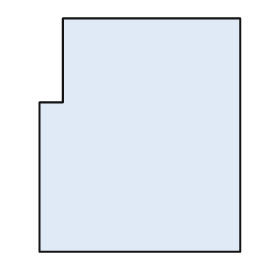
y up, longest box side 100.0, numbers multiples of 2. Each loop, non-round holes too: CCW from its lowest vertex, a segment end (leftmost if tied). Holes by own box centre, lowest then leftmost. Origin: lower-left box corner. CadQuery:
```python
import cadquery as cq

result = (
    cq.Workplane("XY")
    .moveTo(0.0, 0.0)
    .lineTo(86.0, 0.0)
    .lineTo(86.0, 100.0)
    .lineTo(10.0, 100.0)
    .lineTo(10.0, 64.0)
    .lineTo(0.0, 64.0)
    .close()
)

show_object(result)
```